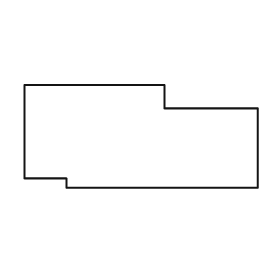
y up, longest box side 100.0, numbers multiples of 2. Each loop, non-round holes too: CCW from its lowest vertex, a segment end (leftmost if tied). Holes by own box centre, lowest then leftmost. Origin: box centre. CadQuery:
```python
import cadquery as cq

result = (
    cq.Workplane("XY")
    .moveTo(-32.0, -22.0)
    .lineTo(50.0, -22.0)
    .lineTo(50.0, 12.0)
    .lineTo(10.0, 12.0)
    .lineTo(10.0, 22.0)
    .lineTo(-50.0, 22.0)
    .lineTo(-50.0, -18.0)
    .lineTo(-32.0, -18.0)
    .close()
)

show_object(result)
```